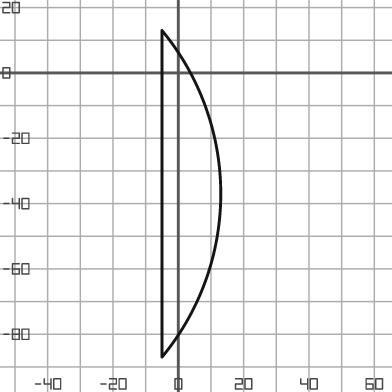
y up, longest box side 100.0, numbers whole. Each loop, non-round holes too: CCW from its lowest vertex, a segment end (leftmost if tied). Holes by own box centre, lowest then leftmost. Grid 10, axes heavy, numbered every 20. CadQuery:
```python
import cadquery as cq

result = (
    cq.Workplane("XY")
    .moveTo(-5.0, -87.0)
    .threePointArc((13.0, -37.0), (-5.0, 13.0))
    .close()
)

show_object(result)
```